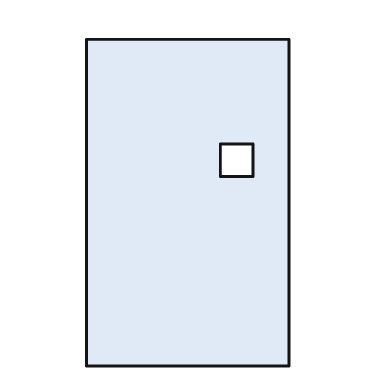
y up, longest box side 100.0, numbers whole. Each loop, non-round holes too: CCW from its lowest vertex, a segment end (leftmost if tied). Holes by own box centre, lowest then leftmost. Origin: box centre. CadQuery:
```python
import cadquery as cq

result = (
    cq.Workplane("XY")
    .moveTo(-31.0, -50.0)
    .lineTo(31.0, -50.0)
    .lineTo(31.0, 50.0)
    .lineTo(-31.0, 50.0)
    .close()
    .moveTo(10.0, 8.0)
    .lineTo(20.0, 8.0)
    .lineTo(20.0, 18.0)
    .lineTo(10.0, 18.0)
    .close()
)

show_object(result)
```